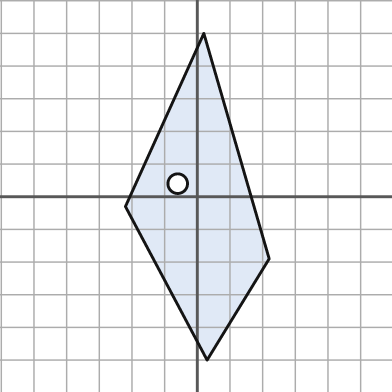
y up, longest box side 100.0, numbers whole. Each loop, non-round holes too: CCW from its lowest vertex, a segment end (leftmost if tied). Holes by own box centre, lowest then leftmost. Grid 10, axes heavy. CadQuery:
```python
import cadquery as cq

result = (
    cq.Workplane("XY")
    .moveTo(3.0, -50.0)
    .lineTo(22.0, -19.0)
    .lineTo(2.0, 50.0)
    .lineTo(-22.0, -3.0)
    .close()
    .moveTo(-6.0, 4.0)
    .circle(3.0)
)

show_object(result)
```